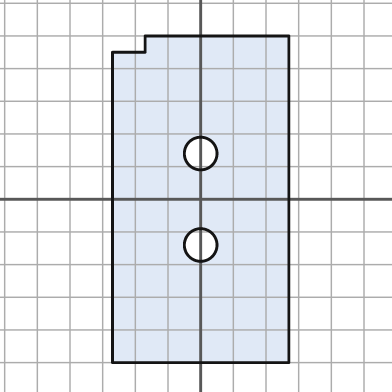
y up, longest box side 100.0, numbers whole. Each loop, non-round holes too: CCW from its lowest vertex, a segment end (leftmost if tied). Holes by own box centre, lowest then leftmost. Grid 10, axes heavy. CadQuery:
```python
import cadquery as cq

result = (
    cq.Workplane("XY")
    .moveTo(-27.0, -50.0)
    .lineTo(27.0, -50.0)
    .lineTo(27.0, 50.0)
    .lineTo(-17.0, 50.0)
    .lineTo(-17.0, 45.0)
    .lineTo(-27.0, 45.0)
    .close()
    .moveTo(0.0, -14.0)
    .circle(5.0)
    .moveTo(0.0, 14.0)
    .circle(5.0)
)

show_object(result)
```